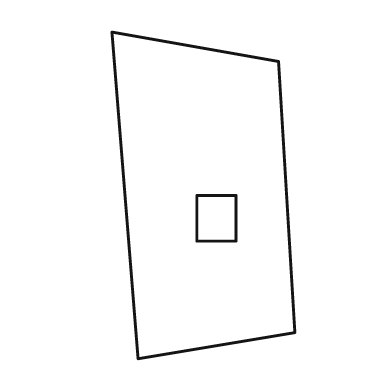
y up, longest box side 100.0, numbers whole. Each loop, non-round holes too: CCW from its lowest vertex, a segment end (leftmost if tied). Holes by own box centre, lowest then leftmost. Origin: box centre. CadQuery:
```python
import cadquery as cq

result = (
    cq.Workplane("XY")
    .moveTo(-20.0, -50.0)
    .lineTo(28.0, -42.0)
    .lineTo(23.0, 41.0)
    .lineTo(-28.0, 50.0)
    .close()
    .moveTo(-2.0, -14.0)
    .lineTo(10.0, -14.0)
    .lineTo(10.0, 0.0)
    .lineTo(-2.0, 0.0)
    .close()
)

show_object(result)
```